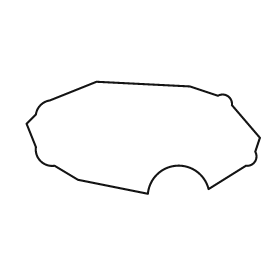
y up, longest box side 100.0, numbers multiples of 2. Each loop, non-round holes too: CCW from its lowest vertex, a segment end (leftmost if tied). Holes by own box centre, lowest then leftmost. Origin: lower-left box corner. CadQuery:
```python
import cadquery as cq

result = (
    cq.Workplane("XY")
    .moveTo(52.0, 0.0)
    .threePointArc((64.0, 12.0), (78.0, 2.0))
    .lineTo(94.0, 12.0)
    .threePointArc((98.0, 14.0), (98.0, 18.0))
    .lineTo(100.0, 24.0)
    .lineTo(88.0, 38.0)
    .threePointArc((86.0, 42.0), (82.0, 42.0))
    .lineTo(70.0, 46.0)
    .lineTo(30.0, 48.0)
    .lineTo(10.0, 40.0)
    .threePointArc((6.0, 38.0), (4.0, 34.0))
    .lineTo(0.0, 30.0)
    .lineTo(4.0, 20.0)
    .threePointArc((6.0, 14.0), (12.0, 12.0))
    .lineTo(22.0, 6.0)
    .close()
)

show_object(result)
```